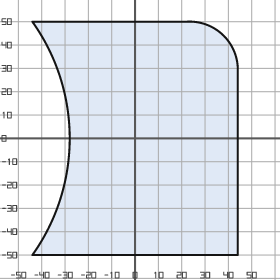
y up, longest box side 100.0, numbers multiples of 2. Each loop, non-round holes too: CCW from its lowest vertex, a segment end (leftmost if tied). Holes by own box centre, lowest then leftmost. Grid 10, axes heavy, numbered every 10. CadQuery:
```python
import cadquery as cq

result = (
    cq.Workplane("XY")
    .moveTo(-44.0, -50.0)
    .lineTo(44.0, -50.0)
    .lineTo(44.0, 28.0)
    .threePointArc((38.0, 44.0), (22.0, 50.0))
    .lineTo(-44.0, 50.0)
    .threePointArc((-28.0, 0.0), (-44.0, -50.0))
    .close()
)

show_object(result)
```